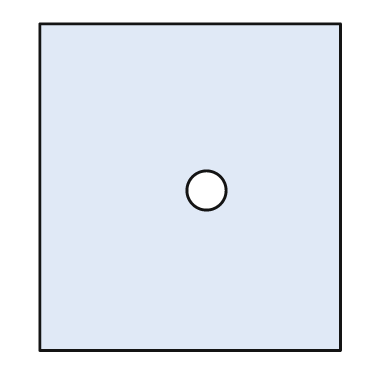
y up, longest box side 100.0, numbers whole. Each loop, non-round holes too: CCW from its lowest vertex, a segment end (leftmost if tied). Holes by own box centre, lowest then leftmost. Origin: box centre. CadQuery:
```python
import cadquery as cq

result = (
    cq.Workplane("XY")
    .moveTo(-46.0, -50.0)
    .lineTo(46.0, -50.0)
    .lineTo(46.0, 50.0)
    .lineTo(-46.0, 50.0)
    .close()
    .moveTo(5.0, -1.0)
    .circle(6.0)
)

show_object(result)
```